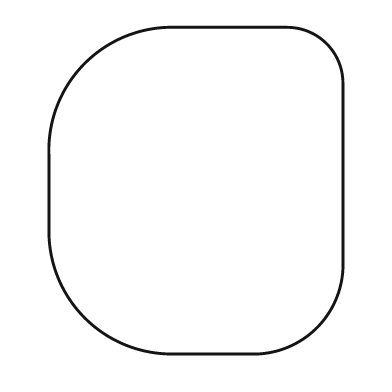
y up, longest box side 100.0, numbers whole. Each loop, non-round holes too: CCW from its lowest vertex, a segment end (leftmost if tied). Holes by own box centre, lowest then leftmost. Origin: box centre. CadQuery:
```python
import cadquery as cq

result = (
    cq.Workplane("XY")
    .moveTo(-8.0, -50.0)
    .lineTo(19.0, -50.0)
    .threePointArc((37.0, -42.0), (45.0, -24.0))
    .lineTo(45.0, 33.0)
    .threePointArc((40.0, 45.0), (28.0, 50.0))
    .lineTo(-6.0, 50.0)
    .threePointArc((-34.0, 39.0), (-45.0, 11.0))
    .lineTo(-45.0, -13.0)
    .threePointArc((-34.0, -39.0), (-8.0, -50.0))
    .close()
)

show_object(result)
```